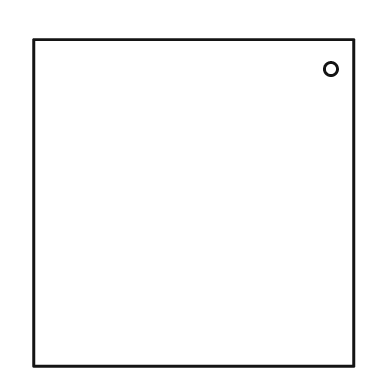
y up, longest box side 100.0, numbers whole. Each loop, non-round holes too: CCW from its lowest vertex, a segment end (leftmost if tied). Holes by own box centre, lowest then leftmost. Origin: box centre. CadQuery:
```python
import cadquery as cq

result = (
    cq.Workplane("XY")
    .moveTo(-49.0, -50.0)
    .lineTo(49.0, -50.0)
    .lineTo(49.0, 50.0)
    .lineTo(-49.0, 50.0)
    .close()
    .moveTo(42.0, 41.0)
    .circle(2.0)
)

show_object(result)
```